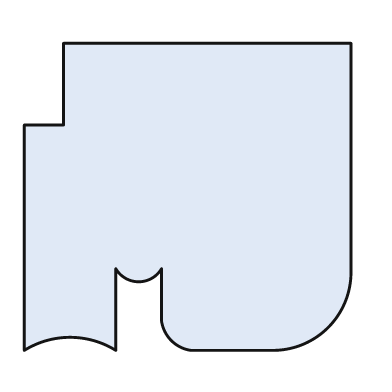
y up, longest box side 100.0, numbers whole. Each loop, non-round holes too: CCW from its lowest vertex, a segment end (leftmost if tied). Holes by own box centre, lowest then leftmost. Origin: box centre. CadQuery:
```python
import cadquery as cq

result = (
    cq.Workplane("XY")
    .moveTo(-50.0, -47.0)
    .threePointArc((-36.0, -43.0), (-22.0, -47.0))
    .lineTo(-22.0, -22.0)
    .threePointArc((-15.0, -26.0), (-8.0, -22.0))
    .lineTo(-8.0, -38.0)
    .threePointArc((-5.0, -44.0), (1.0, -47.0))
    .lineTo(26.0, -47.0)
    .threePointArc((43.0, -40.0), (50.0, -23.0))
    .lineTo(50.0, 47.0)
    .lineTo(-38.0, 47.0)
    .lineTo(-38.0, 22.0)
    .lineTo(-50.0, 22.0)
    .close()
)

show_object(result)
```